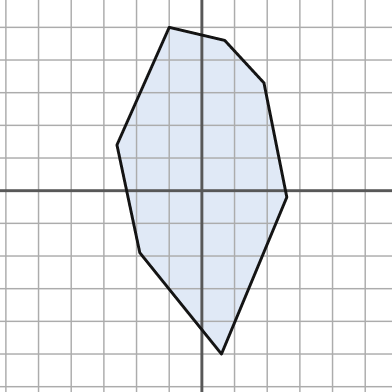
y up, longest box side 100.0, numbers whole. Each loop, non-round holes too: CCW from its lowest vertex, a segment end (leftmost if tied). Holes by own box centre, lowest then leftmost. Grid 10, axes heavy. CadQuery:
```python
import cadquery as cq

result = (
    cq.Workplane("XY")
    .moveTo(6.0, -50.0)
    .lineTo(26.0, -2.0)
    .lineTo(19.0, 33.0)
    .lineTo(7.0, 46.0)
    .lineTo(-10.0, 50.0)
    .lineTo(-26.0, 14.0)
    .lineTo(-19.0, -19.0)
    .close()
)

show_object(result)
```